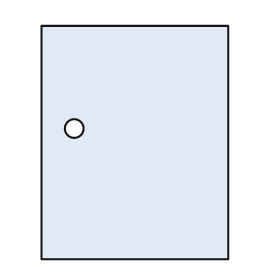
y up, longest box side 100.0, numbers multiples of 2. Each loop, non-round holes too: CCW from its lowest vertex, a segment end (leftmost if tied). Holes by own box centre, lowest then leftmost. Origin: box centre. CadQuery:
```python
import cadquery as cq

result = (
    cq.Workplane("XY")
    .moveTo(-40.0, -50.0)
    .lineTo(40.0, -50.0)
    .lineTo(40.0, 50.0)
    .lineTo(-40.0, 50.0)
    .close()
    .moveTo(-26.0, 6.0)
    .circle(4.0)
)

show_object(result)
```